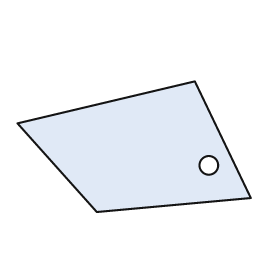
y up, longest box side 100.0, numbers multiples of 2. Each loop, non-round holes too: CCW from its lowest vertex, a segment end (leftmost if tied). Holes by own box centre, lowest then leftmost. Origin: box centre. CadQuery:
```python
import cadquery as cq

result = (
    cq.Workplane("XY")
    .moveTo(-16.0, -28.0)
    .lineTo(50.0, -22.0)
    .lineTo(26.0, 28.0)
    .lineTo(-50.0, 10.0)
    .close()
    .moveTo(32.0, -8.0)
    .circle(4.0)
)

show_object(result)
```